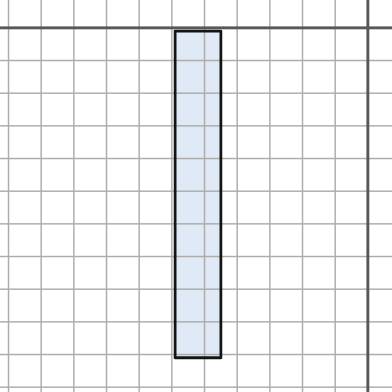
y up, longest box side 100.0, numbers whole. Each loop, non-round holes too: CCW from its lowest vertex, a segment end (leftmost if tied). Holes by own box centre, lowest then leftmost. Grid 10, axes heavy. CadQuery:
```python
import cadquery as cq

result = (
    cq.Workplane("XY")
    .moveTo(-59.0, -101.0)
    .lineTo(-45.0, -101.0)
    .lineTo(-45.0, -1.0)
    .lineTo(-59.0, -1.0)
    .close()
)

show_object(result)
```